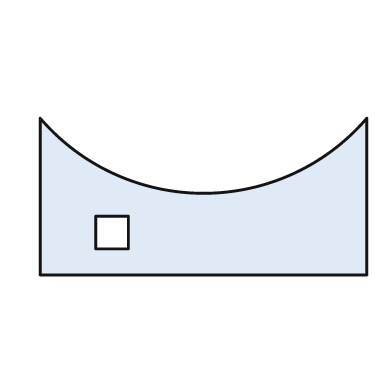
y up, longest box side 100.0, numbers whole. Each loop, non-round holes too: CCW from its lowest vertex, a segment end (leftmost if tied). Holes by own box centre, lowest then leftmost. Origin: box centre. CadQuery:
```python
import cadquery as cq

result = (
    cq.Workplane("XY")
    .moveTo(-50.0, -24.0)
    .lineTo(50.0, -24.0)
    .lineTo(50.0, 24.0)
    .threePointArc((0.0, 1.0), (-50.0, 24.0))
    .close()
    .moveTo(-33.0, -16.0)
    .lineTo(-23.0, -16.0)
    .lineTo(-23.0, -6.0)
    .lineTo(-33.0, -6.0)
    .close()
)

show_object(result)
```